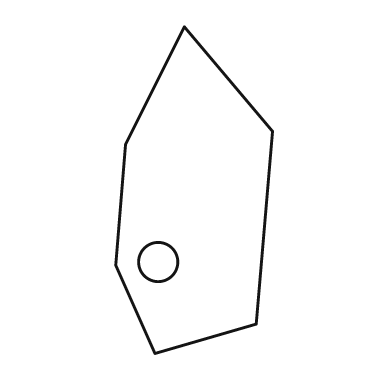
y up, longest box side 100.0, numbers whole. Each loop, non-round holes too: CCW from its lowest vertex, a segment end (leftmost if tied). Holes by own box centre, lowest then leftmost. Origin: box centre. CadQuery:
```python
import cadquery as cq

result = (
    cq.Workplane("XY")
    .moveTo(-12.0, -50.0)
    .lineTo(19.0, -41.0)
    .lineTo(24.0, 18.0)
    .lineTo(-3.0, 50.0)
    .lineTo(-21.0, 14.0)
    .lineTo(-24.0, -23.0)
    .close()
    .moveTo(-11.0, -22.0)
    .circle(6.0)
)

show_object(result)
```